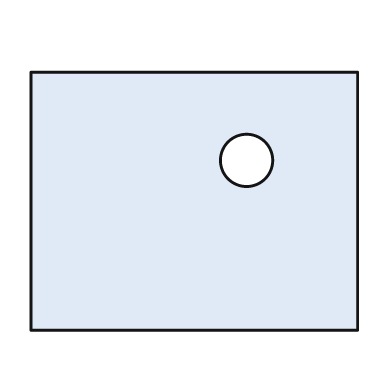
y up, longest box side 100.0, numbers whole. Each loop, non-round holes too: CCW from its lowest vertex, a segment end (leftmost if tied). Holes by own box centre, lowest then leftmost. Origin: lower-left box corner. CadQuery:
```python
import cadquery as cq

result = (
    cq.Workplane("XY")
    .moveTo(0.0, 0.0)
    .lineTo(100.0, 0.0)
    .lineTo(100.0, 79.0)
    .lineTo(0.0, 79.0)
    .close()
    .moveTo(66.0, 52.0)
    .circle(8.0)
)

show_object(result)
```